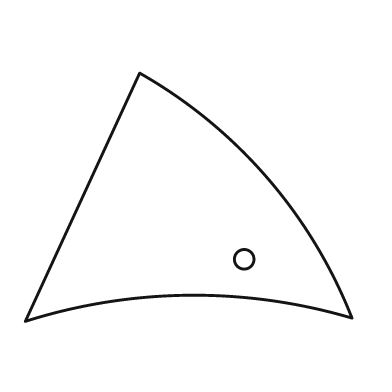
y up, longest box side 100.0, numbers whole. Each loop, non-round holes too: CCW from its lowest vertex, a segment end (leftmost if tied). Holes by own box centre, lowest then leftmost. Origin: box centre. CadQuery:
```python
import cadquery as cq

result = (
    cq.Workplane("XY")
    .moveTo(-50.0, -38.0)
    .threePointArc((0.0, -30.0), (50.0, -37.0))
    .threePointArc((24.0, 6.0), (-15.0, 38.0))
    .close()
    .moveTo(17.0, -19.0)
    .circle(3.0)
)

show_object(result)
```